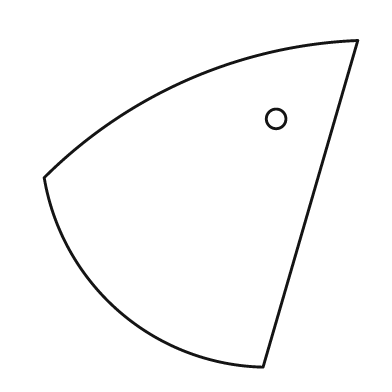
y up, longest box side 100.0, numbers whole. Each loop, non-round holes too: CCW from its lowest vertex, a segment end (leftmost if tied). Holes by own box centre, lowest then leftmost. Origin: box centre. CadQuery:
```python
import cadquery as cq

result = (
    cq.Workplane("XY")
    .moveTo(19.0, -50.0)
    .lineTo(48.0, 50.0)
    .threePointArc((-4.0, 38.0), (-48.0, 8.0))
    .threePointArc((-25.0, -33.0), (19.0, -50.0))
    .close()
    .moveTo(23.0, 26.0)
    .circle(3.0)
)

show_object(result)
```